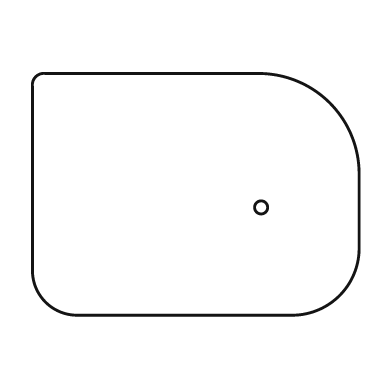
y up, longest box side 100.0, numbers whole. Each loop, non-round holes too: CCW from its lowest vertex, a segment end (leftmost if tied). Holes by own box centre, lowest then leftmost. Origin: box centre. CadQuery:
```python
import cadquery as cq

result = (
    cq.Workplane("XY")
    .moveTo(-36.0, -37.0)
    .lineTo(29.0, -37.0)
    .threePointArc((44.0, -31.0), (50.0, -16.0))
    .lineTo(50.0, 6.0)
    .threePointArc((41.0, 28.0), (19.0, 37.0))
    .lineTo(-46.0, 37.0)
    .threePointArc((-49.0, 36.0), (-50.0, 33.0))
    .lineTo(-50.0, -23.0)
    .threePointArc((-46.0, -33.0), (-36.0, -37.0))
    .close()
    .moveTo(20.0, -4.0)
    .circle(2.0)
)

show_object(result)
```